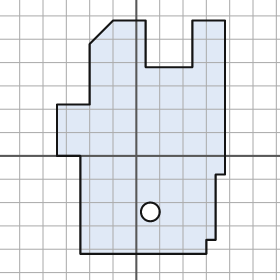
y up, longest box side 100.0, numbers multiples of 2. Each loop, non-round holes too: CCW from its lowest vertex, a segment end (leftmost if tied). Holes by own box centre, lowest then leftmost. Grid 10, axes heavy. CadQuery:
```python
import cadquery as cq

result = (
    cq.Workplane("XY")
    .moveTo(-24.0, -42.0)
    .lineTo(30.0, -42.0)
    .lineTo(30.0, -36.0)
    .lineTo(34.0, -36.0)
    .lineTo(34.0, -8.0)
    .lineTo(38.0, -8.0)
    .lineTo(38.0, 58.0)
    .lineTo(24.0, 58.0)
    .lineTo(24.0, 38.0)
    .lineTo(4.0, 38.0)
    .lineTo(4.0, 58.0)
    .lineTo(-10.0, 58.0)
    .lineTo(-20.0, 48.0)
    .lineTo(-20.0, 22.0)
    .lineTo(-34.0, 22.0)
    .lineTo(-34.0, 0.0)
    .lineTo(-24.0, 0.0)
    .close()
    .moveTo(6.0, -24.0)
    .circle(4.0)
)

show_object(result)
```